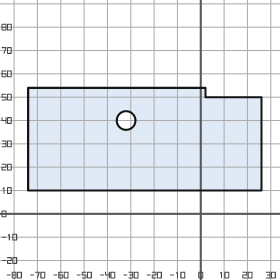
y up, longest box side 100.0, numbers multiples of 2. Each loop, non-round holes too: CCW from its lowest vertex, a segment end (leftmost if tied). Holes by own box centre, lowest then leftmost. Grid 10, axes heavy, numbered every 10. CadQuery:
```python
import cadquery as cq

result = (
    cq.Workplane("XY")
    .moveTo(-74.0, 10.0)
    .lineTo(26.0, 10.0)
    .lineTo(26.0, 50.0)
    .lineTo(2.0, 50.0)
    .lineTo(2.0, 54.0)
    .lineTo(-74.0, 54.0)
    .close()
    .moveTo(-32.0, 40.0)
    .circle(4.0)
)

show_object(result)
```